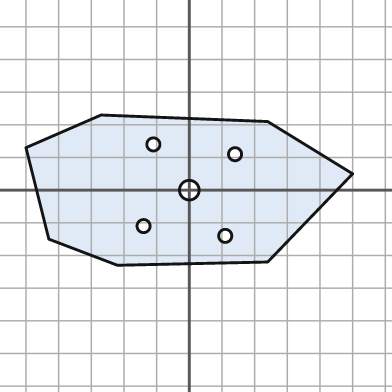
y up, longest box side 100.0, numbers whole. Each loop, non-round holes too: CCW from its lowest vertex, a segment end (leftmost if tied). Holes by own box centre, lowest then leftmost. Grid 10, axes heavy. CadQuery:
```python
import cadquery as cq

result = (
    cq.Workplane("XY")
    .moveTo(-22.0, -23.0)
    .lineTo(24.0, -22.0)
    .lineTo(50.0, 5.0)
    .lineTo(24.0, 21.0)
    .lineTo(-27.0, 23.0)
    .lineTo(-50.0, 13.0)
    .lineTo(-43.0, -15.0)
    .close()
    .moveTo(11.0, -14.0)
    .circle(2.0)
    .moveTo(-14.0, -11.0)
    .circle(2.0)
    .moveTo(0.0, 0.0)
    .circle(3.0)
    .moveTo(14.0, 11.0)
    .circle(2.0)
    .moveTo(-11.0, 14.0)
    .circle(2.0)
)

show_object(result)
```